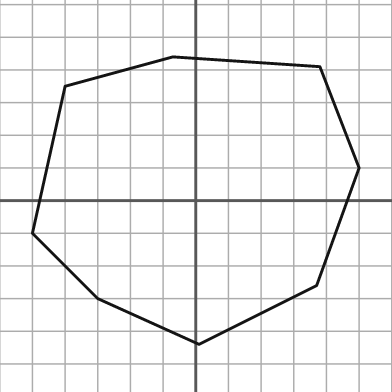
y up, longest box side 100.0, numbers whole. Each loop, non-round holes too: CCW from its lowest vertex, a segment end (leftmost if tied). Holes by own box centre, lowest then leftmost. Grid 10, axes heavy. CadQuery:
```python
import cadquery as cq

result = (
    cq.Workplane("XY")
    .moveTo(1.0, -44.0)
    .lineTo(37.0, -26.0)
    .lineTo(50.0, 10.0)
    .lineTo(38.0, 41.0)
    .lineTo(-7.0, 44.0)
    .lineTo(-40.0, 35.0)
    .lineTo(-50.0, -10.0)
    .lineTo(-30.0, -30.0)
    .close()
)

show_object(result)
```